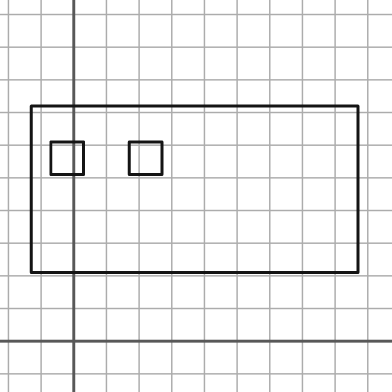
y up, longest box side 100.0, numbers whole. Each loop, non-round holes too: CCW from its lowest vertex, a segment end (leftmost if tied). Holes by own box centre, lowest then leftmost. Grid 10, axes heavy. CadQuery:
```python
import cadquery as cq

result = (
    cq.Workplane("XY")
    .moveTo(-13.0, 21.0)
    .lineTo(87.0, 21.0)
    .lineTo(87.0, 72.0)
    .lineTo(-13.0, 72.0)
    .close()
    .moveTo(-7.0, 51.0)
    .lineTo(3.0, 51.0)
    .lineTo(3.0, 61.0)
    .lineTo(-7.0, 61.0)
    .close()
    .moveTo(17.0, 51.0)
    .lineTo(27.0, 51.0)
    .lineTo(27.0, 61.0)
    .lineTo(17.0, 61.0)
    .close()
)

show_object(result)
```